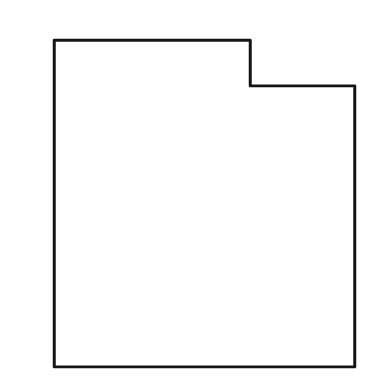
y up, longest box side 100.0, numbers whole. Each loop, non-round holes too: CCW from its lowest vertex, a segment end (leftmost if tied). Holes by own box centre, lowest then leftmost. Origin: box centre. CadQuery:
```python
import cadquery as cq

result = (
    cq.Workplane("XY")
    .moveTo(-46.0, -50.0)
    .lineTo(46.0, -50.0)
    .lineTo(46.0, 36.0)
    .lineTo(14.0, 36.0)
    .lineTo(14.0, 50.0)
    .lineTo(-46.0, 50.0)
    .close()
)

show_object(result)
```